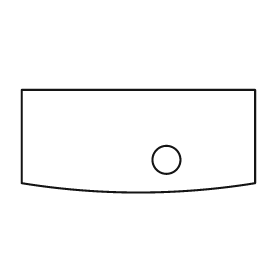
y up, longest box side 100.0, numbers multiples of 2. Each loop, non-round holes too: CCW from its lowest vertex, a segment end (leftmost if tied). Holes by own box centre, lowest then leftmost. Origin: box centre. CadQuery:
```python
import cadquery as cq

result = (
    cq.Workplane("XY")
    .moveTo(-50.0, -18.0)
    .threePointArc((0.0, -22.0), (50.0, -18.0))
    .lineTo(50.0, 22.0)
    .lineTo(-50.0, 22.0)
    .close()
    .moveTo(12.0, -8.0)
    .circle(6.0)
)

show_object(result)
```